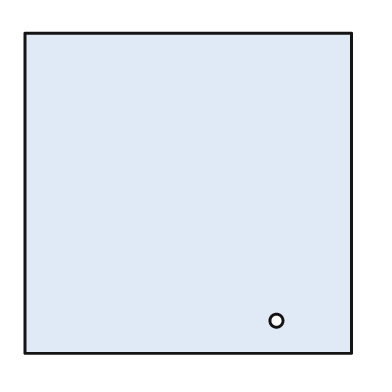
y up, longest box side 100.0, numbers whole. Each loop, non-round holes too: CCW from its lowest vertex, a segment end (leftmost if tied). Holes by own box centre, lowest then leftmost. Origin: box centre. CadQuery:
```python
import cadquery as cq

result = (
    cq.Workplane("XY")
    .moveTo(-50.0, -49.0)
    .lineTo(50.0, -49.0)
    .lineTo(50.0, 49.0)
    .lineTo(-50.0, 49.0)
    .close()
    .moveTo(27.0, -39.0)
    .circle(2.0)
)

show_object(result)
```